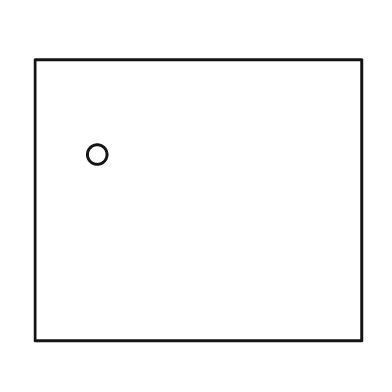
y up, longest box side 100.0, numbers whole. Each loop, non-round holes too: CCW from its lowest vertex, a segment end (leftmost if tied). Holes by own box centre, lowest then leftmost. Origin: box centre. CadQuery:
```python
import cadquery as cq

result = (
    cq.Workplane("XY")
    .moveTo(-50.0, -43.0)
    .lineTo(50.0, -43.0)
    .lineTo(50.0, 43.0)
    .lineTo(-50.0, 43.0)
    .close()
    .moveTo(-31.0, 14.0)
    .circle(3.0)
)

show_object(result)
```